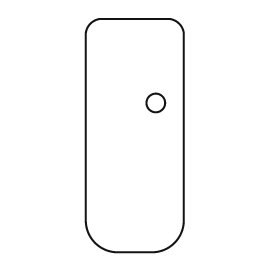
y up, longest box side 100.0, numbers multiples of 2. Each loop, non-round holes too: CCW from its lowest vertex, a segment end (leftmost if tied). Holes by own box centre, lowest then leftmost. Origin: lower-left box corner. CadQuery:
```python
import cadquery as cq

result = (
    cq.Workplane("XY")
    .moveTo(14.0, 0.0)
    .lineTo(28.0, 0.0)
    .threePointArc((38.0, 4.0), (42.0, 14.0))
    .lineTo(42.0, 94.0)
    .threePointArc((40.0, 98.0), (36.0, 100.0))
    .lineTo(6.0, 100.0)
    .threePointArc((2.0, 98.0), (0.0, 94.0))
    .lineTo(0.0, 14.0)
    .threePointArc((4.0, 4.0), (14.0, 0.0))
    .close()
    .moveTo(30.0, 64.0)
    .circle(4.0)
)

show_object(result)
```